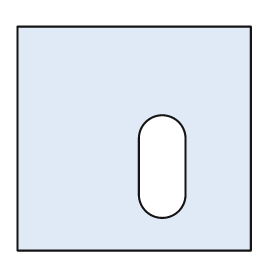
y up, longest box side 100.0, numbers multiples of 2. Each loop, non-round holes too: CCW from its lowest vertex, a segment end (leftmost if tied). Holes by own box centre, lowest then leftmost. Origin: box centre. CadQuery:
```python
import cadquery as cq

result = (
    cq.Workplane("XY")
    .moveTo(-50.0, -48.0)
    .lineTo(50.0, -48.0)
    .lineTo(50.0, 48.0)
    .lineTo(-50.0, 48.0)
    .close()
    .moveTo(2.0, -24.0)
    .threePointArc((12.0, -34.0), (22.0, -24.0))
    .lineTo(22.0, 0.0)
    .threePointArc((12.0, 10.0), (2.0, 0.0))
    .close()
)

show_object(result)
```